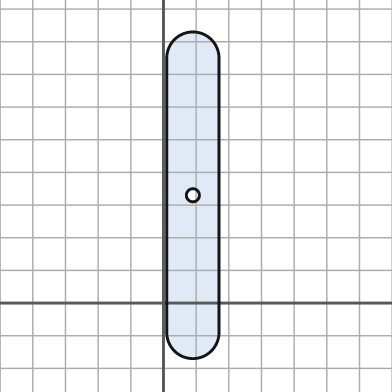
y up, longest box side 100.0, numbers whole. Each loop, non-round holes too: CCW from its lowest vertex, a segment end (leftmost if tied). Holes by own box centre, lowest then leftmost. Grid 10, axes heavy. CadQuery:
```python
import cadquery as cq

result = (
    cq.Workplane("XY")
    .moveTo(1.0, -9.0)
    .threePointArc((9.0, -17.0), (17.0, -9.0))
    .lineTo(17.0, 75.0)
    .threePointArc((9.0, 83.0), (1.0, 75.0))
    .close()
    .moveTo(9.0, 33.0)
    .circle(2.0)
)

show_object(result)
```